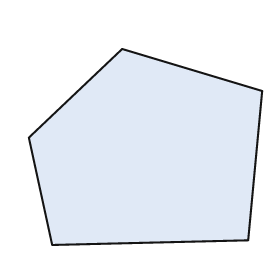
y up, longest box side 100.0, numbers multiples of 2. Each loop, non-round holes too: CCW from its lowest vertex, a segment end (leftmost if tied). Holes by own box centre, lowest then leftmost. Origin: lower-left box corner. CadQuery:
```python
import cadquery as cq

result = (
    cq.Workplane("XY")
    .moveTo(10.0, 0.0)
    .lineTo(94.0, 2.0)
    .lineTo(100.0, 66.0)
    .lineTo(40.0, 84.0)
    .lineTo(0.0, 46.0)
    .close()
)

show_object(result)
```